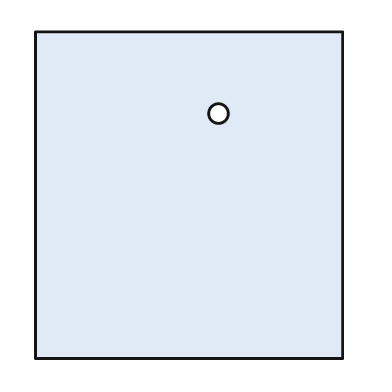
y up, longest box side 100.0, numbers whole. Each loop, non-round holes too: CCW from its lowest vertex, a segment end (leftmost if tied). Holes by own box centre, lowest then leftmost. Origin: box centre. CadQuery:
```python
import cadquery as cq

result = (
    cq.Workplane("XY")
    .moveTo(-47.0, -50.0)
    .lineTo(47.0, -50.0)
    .lineTo(47.0, 50.0)
    .lineTo(-47.0, 50.0)
    .close()
    .moveTo(9.0, 25.0)
    .circle(3.0)
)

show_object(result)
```